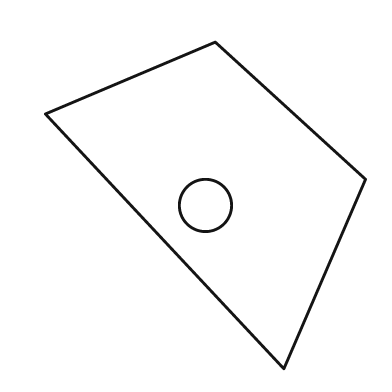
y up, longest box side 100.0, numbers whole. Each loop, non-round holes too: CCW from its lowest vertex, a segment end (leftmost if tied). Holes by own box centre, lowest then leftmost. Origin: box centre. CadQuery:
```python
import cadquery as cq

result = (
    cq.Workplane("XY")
    .moveTo(24.0, -50.0)
    .lineTo(49.0, 8.0)
    .lineTo(3.0, 50.0)
    .lineTo(-49.0, 28.0)
    .close()
    .moveTo(0.0, 0.0)
    .circle(8.0)
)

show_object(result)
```